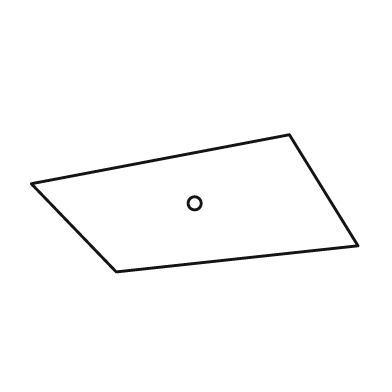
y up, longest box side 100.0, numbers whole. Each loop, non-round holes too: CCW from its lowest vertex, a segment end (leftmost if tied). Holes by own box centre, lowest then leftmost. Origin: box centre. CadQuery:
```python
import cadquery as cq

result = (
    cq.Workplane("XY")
    .moveTo(-24.0, -21.0)
    .lineTo(50.0, -13.0)
    .lineTo(29.0, 21.0)
    .lineTo(-50.0, 6.0)
    .close()
    .moveTo(0.0, 0.0)
    .circle(2.0)
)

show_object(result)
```